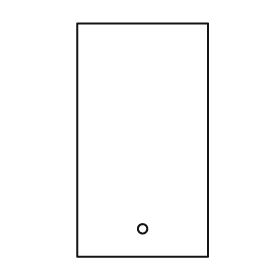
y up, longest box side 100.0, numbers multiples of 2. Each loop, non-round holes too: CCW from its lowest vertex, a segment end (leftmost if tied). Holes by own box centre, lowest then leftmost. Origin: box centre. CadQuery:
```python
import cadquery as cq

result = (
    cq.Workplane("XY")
    .moveTo(-28.0, -50.0)
    .lineTo(28.0, -50.0)
    .lineTo(28.0, 50.0)
    .lineTo(-28.0, 50.0)
    .close()
    .moveTo(0.0, -38.0)
    .circle(2.0)
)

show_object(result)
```